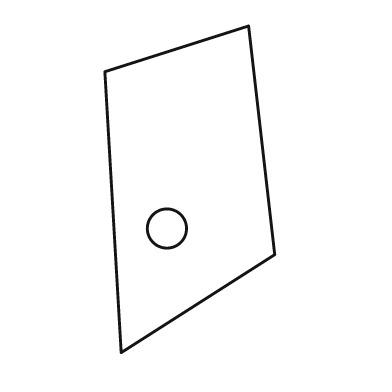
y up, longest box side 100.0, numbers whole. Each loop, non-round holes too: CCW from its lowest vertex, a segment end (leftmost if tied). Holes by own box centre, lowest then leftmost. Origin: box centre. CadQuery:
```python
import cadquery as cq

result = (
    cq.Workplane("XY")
    .moveTo(-21.0, -50.0)
    .lineTo(26.0, -20.0)
    .lineTo(18.0, 50.0)
    .lineTo(-26.0, 36.0)
    .close()
    .moveTo(-7.0, -12.0)
    .circle(6.0)
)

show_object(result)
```